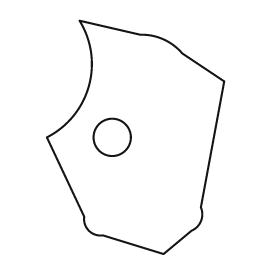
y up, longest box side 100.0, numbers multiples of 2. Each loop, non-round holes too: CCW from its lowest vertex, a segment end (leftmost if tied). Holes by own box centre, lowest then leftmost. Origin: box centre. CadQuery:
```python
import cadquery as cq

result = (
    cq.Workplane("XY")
    .moveTo(12.0, -50.0)
    .lineTo(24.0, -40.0)
    .threePointArc((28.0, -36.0), (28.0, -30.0))
    .lineTo(38.0, 24.0)
    .lineTo(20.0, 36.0)
    .threePointArc((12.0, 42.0), (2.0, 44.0))
    .lineTo(-24.0, 50.0)
    .threePointArc((-20.0, 22.0), (-38.0, 0.0))
    .lineTo(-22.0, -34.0)
    .threePointArc((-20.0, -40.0), (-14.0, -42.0))
    .close()
    .moveTo(-10.0, 0.0)
    .circle(8.0)
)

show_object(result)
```